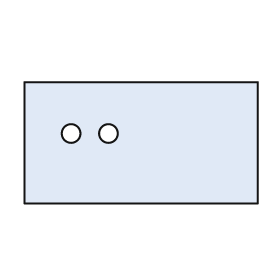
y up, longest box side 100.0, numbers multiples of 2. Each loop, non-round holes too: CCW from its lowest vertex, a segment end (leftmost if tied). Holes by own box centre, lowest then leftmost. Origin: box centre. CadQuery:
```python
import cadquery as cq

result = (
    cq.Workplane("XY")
    .moveTo(-50.0, -26.0)
    .lineTo(50.0, -26.0)
    .lineTo(50.0, 26.0)
    .lineTo(-50.0, 26.0)
    .close()
    .moveTo(-30.0, 4.0)
    .circle(4.0)
    .moveTo(-14.0, 4.0)
    .circle(4.0)
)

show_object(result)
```